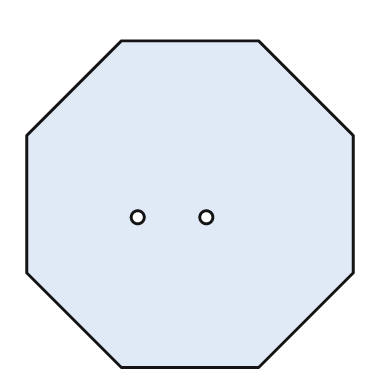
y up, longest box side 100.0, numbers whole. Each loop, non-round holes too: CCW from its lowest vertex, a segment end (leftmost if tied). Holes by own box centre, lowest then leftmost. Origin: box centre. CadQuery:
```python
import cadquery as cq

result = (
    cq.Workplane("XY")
    .moveTo(-21.0, -50.0)
    .lineTo(21.0, -50.0)
    .lineTo(50.0, -21.0)
    .lineTo(50.0, 21.0)
    .lineTo(21.0, 50.0)
    .lineTo(-21.0, 50.0)
    .lineTo(-50.0, 21.0)
    .lineTo(-50.0, -21.0)
    .close()
    .moveTo(-16.0, -4.0)
    .circle(2.0)
    .moveTo(5.0, -4.0)
    .circle(2.0)
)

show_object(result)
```